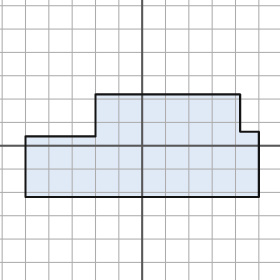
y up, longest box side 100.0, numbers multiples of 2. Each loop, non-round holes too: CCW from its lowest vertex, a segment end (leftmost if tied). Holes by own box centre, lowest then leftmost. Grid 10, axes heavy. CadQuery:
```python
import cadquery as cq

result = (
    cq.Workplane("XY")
    .moveTo(-50.0, -22.0)
    .lineTo(50.0, -22.0)
    .lineTo(50.0, 6.0)
    .lineTo(42.0, 6.0)
    .lineTo(42.0, 22.0)
    .lineTo(-20.0, 22.0)
    .lineTo(-20.0, 4.0)
    .lineTo(-50.0, 4.0)
    .close()
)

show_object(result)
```